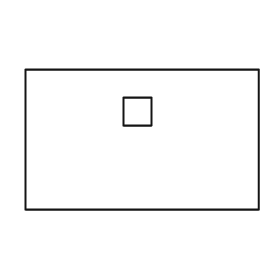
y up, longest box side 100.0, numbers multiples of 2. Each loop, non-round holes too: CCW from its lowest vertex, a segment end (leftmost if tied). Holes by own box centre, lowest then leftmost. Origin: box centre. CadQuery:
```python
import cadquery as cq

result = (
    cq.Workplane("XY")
    .moveTo(-50.0, -30.0)
    .lineTo(50.0, -30.0)
    .lineTo(50.0, 30.0)
    .lineTo(-50.0, 30.0)
    .close()
    .moveTo(-8.0, 6.0)
    .lineTo(4.0, 6.0)
    .lineTo(4.0, 18.0)
    .lineTo(-8.0, 18.0)
    .close()
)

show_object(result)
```